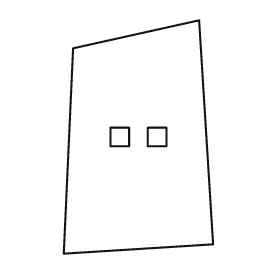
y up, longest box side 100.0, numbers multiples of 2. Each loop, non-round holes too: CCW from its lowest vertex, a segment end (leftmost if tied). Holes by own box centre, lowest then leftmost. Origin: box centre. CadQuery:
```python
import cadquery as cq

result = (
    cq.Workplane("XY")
    .moveTo(-32.0, -50.0)
    .lineTo(32.0, -46.0)
    .lineTo(26.0, 50.0)
    .lineTo(-28.0, 38.0)
    .close()
    .moveTo(-12.0, -4.0)
    .lineTo(-4.0, -4.0)
    .lineTo(-4.0, 4.0)
    .lineTo(-12.0, 4.0)
    .close()
    .moveTo(4.0, -4.0)
    .lineTo(12.0, -4.0)
    .lineTo(12.0, 4.0)
    .lineTo(4.0, 4.0)
    .close()
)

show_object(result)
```